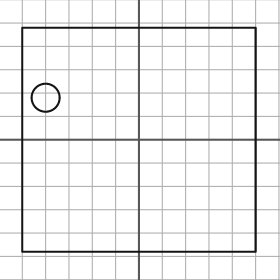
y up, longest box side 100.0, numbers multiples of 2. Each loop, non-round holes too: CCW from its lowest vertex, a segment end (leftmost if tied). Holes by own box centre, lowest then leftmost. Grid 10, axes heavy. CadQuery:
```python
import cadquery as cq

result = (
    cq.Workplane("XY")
    .moveTo(-50.0, -48.0)
    .lineTo(50.0, -48.0)
    .lineTo(50.0, 48.0)
    .lineTo(-50.0, 48.0)
    .close()
    .moveTo(-40.0, 18.0)
    .circle(6.0)
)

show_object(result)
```